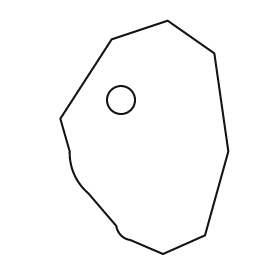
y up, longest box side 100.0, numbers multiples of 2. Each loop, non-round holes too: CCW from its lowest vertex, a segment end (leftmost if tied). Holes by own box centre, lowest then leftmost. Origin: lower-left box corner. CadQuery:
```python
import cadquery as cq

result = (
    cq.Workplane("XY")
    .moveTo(44.0, 0.0)
    .lineTo(62.0, 8.0)
    .lineTo(72.0, 44.0)
    .lineTo(66.0, 86.0)
    .lineTo(46.0, 100.0)
    .lineTo(22.0, 92.0)
    .lineTo(0.0, 58.0)
    .lineTo(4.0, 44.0)
    .threePointArc((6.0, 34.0), (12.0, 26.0))
    .lineTo(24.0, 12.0)
    .threePointArc((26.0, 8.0), (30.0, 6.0))
    .close()
    .moveTo(26.0, 66.0)
    .circle(6.0)
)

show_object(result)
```